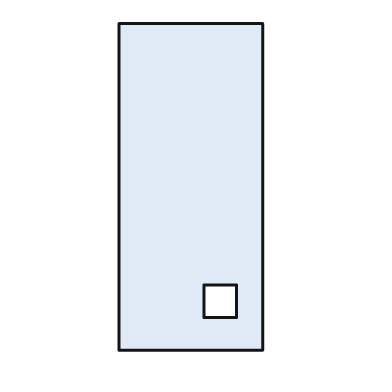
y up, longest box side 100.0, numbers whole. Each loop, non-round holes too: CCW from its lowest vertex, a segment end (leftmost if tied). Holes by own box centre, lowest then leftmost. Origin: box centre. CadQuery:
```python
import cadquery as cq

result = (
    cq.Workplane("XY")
    .moveTo(-22.0, -50.0)
    .lineTo(22.0, -50.0)
    .lineTo(22.0, 50.0)
    .lineTo(-22.0, 50.0)
    .close()
    .moveTo(4.0, -40.0)
    .lineTo(14.0, -40.0)
    .lineTo(14.0, -30.0)
    .lineTo(4.0, -30.0)
    .close()
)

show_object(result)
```